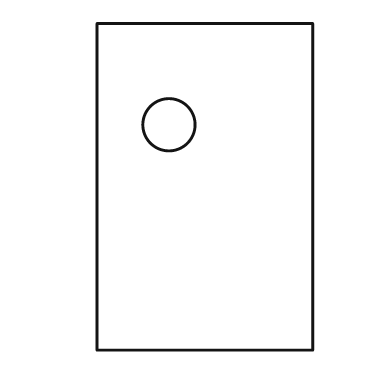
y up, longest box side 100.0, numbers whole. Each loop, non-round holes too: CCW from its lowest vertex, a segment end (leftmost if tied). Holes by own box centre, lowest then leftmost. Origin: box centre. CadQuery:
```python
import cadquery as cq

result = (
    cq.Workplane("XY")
    .moveTo(-33.0, -50.0)
    .lineTo(33.0, -50.0)
    .lineTo(33.0, 50.0)
    .lineTo(-33.0, 50.0)
    .close()
    .moveTo(-11.0, 19.0)
    .circle(8.0)
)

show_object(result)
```